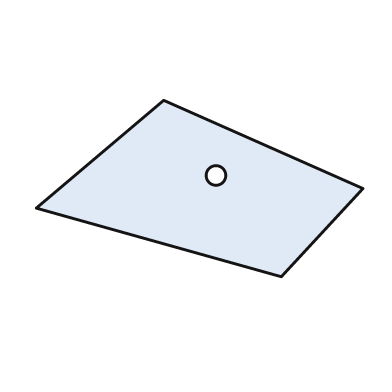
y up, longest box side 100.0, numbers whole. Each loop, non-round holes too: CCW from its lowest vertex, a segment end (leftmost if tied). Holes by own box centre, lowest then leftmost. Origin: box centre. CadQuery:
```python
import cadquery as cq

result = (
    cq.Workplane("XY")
    .moveTo(25.0, -27.0)
    .lineTo(50.0, 0.0)
    .lineTo(-11.0, 27.0)
    .lineTo(-50.0, -6.0)
    .close()
    .moveTo(5.0, 4.0)
    .circle(3.0)
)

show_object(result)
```